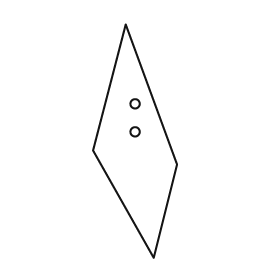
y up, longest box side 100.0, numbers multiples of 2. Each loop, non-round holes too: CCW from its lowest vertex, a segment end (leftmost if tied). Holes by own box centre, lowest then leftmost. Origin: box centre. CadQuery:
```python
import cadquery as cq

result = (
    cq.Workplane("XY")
    .moveTo(8.0, -50.0)
    .lineTo(18.0, -10.0)
    .lineTo(-4.0, 50.0)
    .lineTo(-18.0, -4.0)
    .close()
    .moveTo(0.0, 4.0)
    .circle(2.0)
    .moveTo(0.0, 16.0)
    .circle(2.0)
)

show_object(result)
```